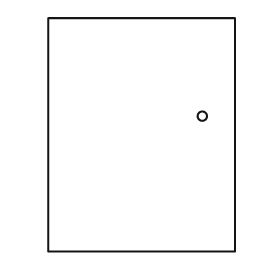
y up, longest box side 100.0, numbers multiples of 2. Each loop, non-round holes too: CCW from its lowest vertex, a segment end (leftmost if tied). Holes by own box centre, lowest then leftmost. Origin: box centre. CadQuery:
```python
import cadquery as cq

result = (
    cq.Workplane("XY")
    .moveTo(-40.0, -50.0)
    .lineTo(40.0, -50.0)
    .lineTo(40.0, 50.0)
    .lineTo(-40.0, 50.0)
    .close()
    .moveTo(26.0, 8.0)
    .circle(2.0)
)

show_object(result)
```